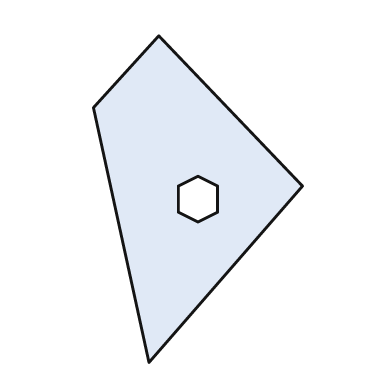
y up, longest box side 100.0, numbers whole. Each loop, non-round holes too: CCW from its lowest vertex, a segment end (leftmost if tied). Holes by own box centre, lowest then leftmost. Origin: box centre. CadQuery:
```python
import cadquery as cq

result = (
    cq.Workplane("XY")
    .moveTo(-15.0, -50.0)
    .lineTo(32.0, 4.0)
    .lineTo(-12.0, 50.0)
    .lineTo(-32.0, 28.0)
    .close()
    .moveTo(0.0, -7.0)
    .lineTo(6.0, -4.0)
    .lineTo(6.0, 4.0)
    .lineTo(0.0, 7.0)
    .lineTo(-6.0, 4.0)
    .lineTo(-6.0, -4.0)
    .close()
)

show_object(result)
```